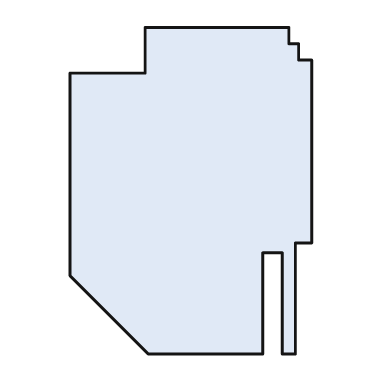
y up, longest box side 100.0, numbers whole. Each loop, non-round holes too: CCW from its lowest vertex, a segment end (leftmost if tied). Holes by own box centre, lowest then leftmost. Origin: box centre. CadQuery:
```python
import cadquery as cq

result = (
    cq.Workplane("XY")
    .moveTo(-13.0, -50.0)
    .lineTo(22.0, -50.0)
    .lineTo(22.0, -19.0)
    .lineTo(28.0, -19.0)
    .lineTo(28.0, -50.0)
    .lineTo(32.0, -50.0)
    .lineTo(32.0, -16.0)
    .lineTo(37.0, -16.0)
    .lineTo(37.0, 40.0)
    .lineTo(33.0, 40.0)
    .lineTo(33.0, 45.0)
    .lineTo(30.0, 45.0)
    .lineTo(30.0, 50.0)
    .lineTo(-14.0, 50.0)
    .lineTo(-14.0, 36.0)
    .lineTo(-37.0, 36.0)
    .lineTo(-37.0, -26.0)
    .close()
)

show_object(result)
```